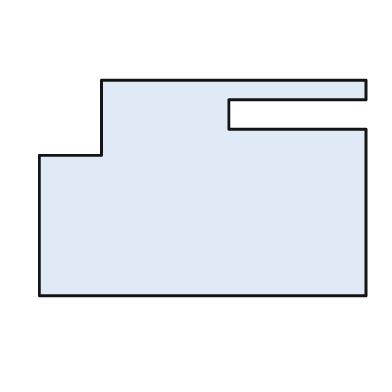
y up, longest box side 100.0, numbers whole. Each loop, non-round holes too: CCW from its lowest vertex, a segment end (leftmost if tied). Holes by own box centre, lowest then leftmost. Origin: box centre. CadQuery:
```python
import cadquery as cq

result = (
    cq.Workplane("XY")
    .moveTo(-50.0, -33.0)
    .lineTo(50.0, -33.0)
    .lineTo(50.0, 18.0)
    .lineTo(8.0, 18.0)
    .lineTo(8.0, 27.0)
    .lineTo(50.0, 27.0)
    .lineTo(50.0, 33.0)
    .lineTo(-31.0, 33.0)
    .lineTo(-31.0, 10.0)
    .lineTo(-50.0, 10.0)
    .close()
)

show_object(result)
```